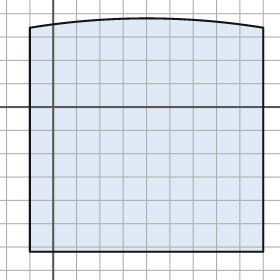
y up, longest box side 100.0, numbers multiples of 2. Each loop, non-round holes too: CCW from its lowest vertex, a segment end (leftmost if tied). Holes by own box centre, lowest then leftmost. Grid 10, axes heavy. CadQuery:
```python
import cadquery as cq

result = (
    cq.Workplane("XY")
    .moveTo(-10.0, -62.0)
    .lineTo(90.0, -62.0)
    .lineTo(90.0, 34.0)
    .threePointArc((40.0, 38.0), (-10.0, 34.0))
    .close()
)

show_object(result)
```